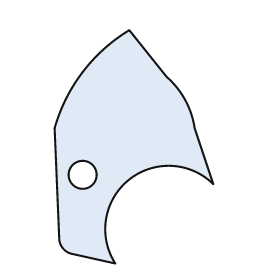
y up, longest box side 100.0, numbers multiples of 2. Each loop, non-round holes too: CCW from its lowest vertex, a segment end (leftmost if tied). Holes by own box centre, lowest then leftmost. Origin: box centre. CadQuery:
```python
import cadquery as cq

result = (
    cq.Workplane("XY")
    .moveTo(-8.0, -50.0)
    .threePointArc((-2.0, -14.0), (34.0, -16.0))
    .lineTo(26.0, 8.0)
    .threePointArc((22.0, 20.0), (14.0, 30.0))
    .lineTo(-2.0, 50.0)
    .threePointArc((-22.0, 32.0), (-34.0, 8.0))
    .lineTo(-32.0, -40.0)
    .threePointArc((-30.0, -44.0), (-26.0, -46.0))
    .close()
    .moveTo(-22.0, -12.0)
    .circle(6.0)
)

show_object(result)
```